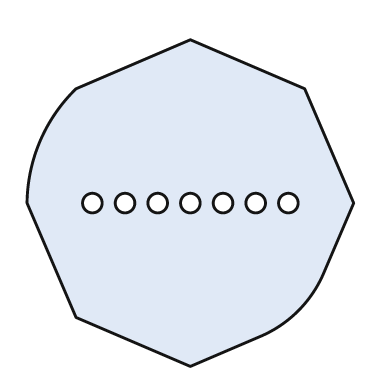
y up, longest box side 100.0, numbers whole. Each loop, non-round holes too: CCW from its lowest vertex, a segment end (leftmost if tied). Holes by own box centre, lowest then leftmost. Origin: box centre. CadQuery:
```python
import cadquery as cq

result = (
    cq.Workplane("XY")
    .moveTo(0.0, -50.0)
    .lineTo(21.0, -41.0)
    .threePointArc((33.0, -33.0), (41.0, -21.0))
    .lineTo(50.0, 0.0)
    .lineTo(35.0, 35.0)
    .lineTo(0.0, 50.0)
    .lineTo(-35.0, 35.0)
    .threePointArc((-46.0, 19.0), (-50.0, 0.0))
    .lineTo(-35.0, -35.0)
    .close()
    .moveTo(-30.0, 0.0)
    .circle(3.0)
    .moveTo(-20.0, 0.0)
    .circle(3.0)
    .moveTo(-10.0, 0.0)
    .circle(3.0)
    .moveTo(0.0, 0.0)
    .circle(3.0)
    .moveTo(10.0, 0.0)
    .circle(3.0)
    .moveTo(20.0, 0.0)
    .circle(3.0)
    .moveTo(30.0, 0.0)
    .circle(3.0)
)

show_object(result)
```